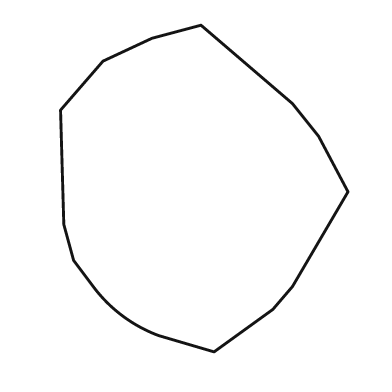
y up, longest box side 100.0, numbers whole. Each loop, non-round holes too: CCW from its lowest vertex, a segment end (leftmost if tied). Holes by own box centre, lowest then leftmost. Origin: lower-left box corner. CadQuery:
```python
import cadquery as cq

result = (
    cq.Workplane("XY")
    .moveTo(47.0, 0.0)
    .lineTo(65.0, 13.0)
    .lineTo(71.0, 20.0)
    .lineTo(88.0, 49.0)
    .lineTo(79.0, 66.0)
    .lineTo(71.0, 76.0)
    .lineTo(43.0, 100.0)
    .lineTo(28.0, 96.0)
    .lineTo(13.0, 89.0)
    .lineTo(0.0, 74.0)
    .lineTo(1.0, 39.0)
    .lineTo(4.0, 28.0)
    .lineTo(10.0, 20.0)
    .threePointArc((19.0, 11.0), (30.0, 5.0))
    .close()
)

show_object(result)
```